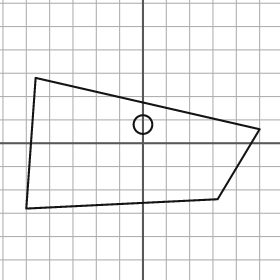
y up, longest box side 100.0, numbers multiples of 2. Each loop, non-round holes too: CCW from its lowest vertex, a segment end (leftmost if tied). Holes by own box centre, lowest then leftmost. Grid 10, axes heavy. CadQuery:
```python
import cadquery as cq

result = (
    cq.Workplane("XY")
    .moveTo(-50.0, -28.0)
    .lineTo(32.0, -24.0)
    .lineTo(50.0, 6.0)
    .lineTo(-46.0, 28.0)
    .close()
    .moveTo(0.0, 8.0)
    .circle(4.0)
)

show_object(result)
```